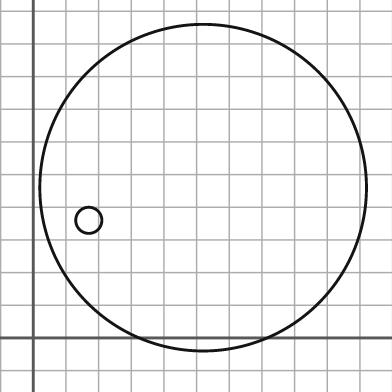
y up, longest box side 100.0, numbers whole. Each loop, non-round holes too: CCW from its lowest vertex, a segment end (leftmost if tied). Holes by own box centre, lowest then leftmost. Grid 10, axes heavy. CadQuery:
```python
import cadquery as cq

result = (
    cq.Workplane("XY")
    .moveTo(52.0, 46.0)
    .circle(50.0)
    .moveTo(17.0, 36.0)
    .circle(4.0)
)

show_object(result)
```